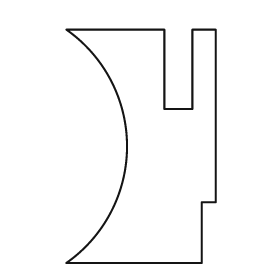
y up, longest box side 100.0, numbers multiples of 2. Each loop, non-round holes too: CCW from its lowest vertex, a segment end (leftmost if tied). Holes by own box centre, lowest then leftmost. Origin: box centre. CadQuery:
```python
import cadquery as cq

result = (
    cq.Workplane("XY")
    .moveTo(-32.0, -50.0)
    .lineTo(26.0, -50.0)
    .lineTo(26.0, -24.0)
    .lineTo(32.0, -24.0)
    .lineTo(32.0, 50.0)
    .lineTo(22.0, 50.0)
    .lineTo(22.0, 16.0)
    .lineTo(10.0, 16.0)
    .lineTo(10.0, 50.0)
    .lineTo(-32.0, 50.0)
    .threePointArc((-6.0, 0.0), (-32.0, -50.0))
    .close()
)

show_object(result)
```